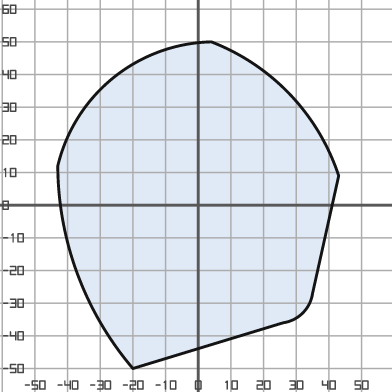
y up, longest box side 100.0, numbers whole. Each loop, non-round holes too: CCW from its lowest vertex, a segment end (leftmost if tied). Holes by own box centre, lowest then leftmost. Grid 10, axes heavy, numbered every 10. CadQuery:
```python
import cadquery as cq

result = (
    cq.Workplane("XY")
    .moveTo(-20.0, -50.0)
    .lineTo(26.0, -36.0)
    .threePointArc((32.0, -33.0), (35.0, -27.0))
    .lineTo(43.0, 9.0)
    .threePointArc((28.0, 34.0), (4.0, 50.0))
    .threePointArc((-26.0, 39.0), (-43.0, 12.0))
    .threePointArc((-37.0, -21.0), (-20.0, -50.0))
    .close()
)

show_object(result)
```